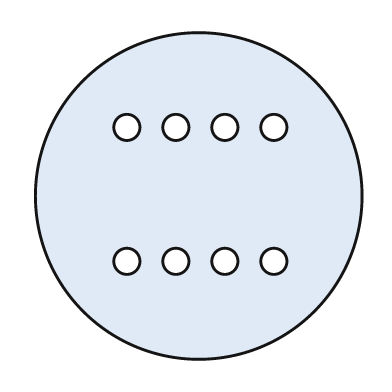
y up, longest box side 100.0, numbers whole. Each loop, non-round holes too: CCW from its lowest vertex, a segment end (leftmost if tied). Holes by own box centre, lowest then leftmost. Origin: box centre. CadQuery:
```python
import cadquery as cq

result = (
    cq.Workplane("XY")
    .moveTo(0.0, 0.0)
    .circle(50.0)
    .moveTo(-22.0, -20.0)
    .circle(4.0)
    .moveTo(-7.0, -20.0)
    .circle(4.0)
    .moveTo(8.0, -20.0)
    .circle(4.0)
    .moveTo(23.0, -20.0)
    .circle(4.0)
    .moveTo(-22.0, 21.0)
    .circle(4.0)
    .moveTo(-7.0, 21.0)
    .circle(4.0)
    .moveTo(8.0, 21.0)
    .circle(4.0)
    .moveTo(23.0, 21.0)
    .circle(4.0)
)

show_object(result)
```